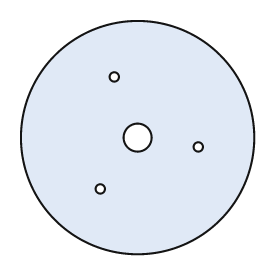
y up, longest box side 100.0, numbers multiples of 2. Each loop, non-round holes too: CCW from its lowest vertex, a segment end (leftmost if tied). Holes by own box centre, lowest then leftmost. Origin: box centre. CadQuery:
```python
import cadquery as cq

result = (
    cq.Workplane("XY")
    .moveTo(0.0, 0.0)
    .circle(50.0)
    .moveTo(-16.0, -22.0)
    .circle(2.0)
    .moveTo(26.0, -4.0)
    .circle(2.0)
    .moveTo(0.0, 0.0)
    .circle(6.0)
    .moveTo(-10.0, 26.0)
    .circle(2.0)
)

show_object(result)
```